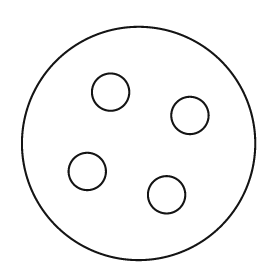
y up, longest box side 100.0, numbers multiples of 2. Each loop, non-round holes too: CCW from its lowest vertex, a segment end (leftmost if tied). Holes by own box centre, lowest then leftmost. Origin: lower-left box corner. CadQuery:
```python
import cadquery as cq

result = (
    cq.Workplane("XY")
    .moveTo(50.0, 50.0)
    .circle(50.0)
    .moveTo(62.0, 28.0)
    .circle(8.0)
    .moveTo(28.0, 38.0)
    .circle(8.0)
    .moveTo(72.0, 62.0)
    .circle(8.0)
    .moveTo(38.0, 72.0)
    .circle(8.0)
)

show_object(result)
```